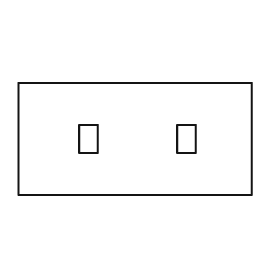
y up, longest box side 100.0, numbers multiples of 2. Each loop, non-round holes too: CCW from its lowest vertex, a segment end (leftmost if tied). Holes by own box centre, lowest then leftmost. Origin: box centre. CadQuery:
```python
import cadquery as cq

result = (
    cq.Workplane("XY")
    .moveTo(-50.0, -24.0)
    .lineTo(50.0, -24.0)
    .lineTo(50.0, 24.0)
    .lineTo(-50.0, 24.0)
    .close()
    .moveTo(-24.0, -6.0)
    .lineTo(-16.0, -6.0)
    .lineTo(-16.0, 6.0)
    .lineTo(-24.0, 6.0)
    .close()
    .moveTo(18.0, -6.0)
    .lineTo(26.0, -6.0)
    .lineTo(26.0, 6.0)
    .lineTo(18.0, 6.0)
    .close()
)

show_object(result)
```